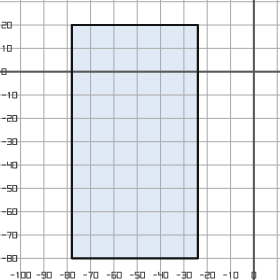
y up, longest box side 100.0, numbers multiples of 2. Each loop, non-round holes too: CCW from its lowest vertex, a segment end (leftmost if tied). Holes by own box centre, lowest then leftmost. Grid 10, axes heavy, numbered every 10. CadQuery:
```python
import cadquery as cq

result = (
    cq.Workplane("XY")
    .moveTo(-78.0, -80.0)
    .lineTo(-24.0, -80.0)
    .lineTo(-24.0, 20.0)
    .lineTo(-78.0, 20.0)
    .close()
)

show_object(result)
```